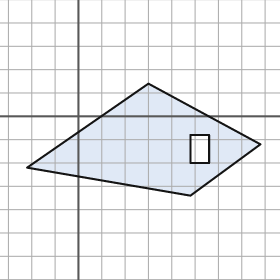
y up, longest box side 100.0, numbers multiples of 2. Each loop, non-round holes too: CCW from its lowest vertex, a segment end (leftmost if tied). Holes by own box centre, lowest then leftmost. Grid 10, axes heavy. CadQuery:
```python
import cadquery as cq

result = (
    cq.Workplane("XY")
    .moveTo(48.0, -34.0)
    .lineTo(78.0, -12.0)
    .lineTo(30.0, 14.0)
    .lineTo(-22.0, -22.0)
    .close()
    .moveTo(48.0, -20.0)
    .lineTo(56.0, -20.0)
    .lineTo(56.0, -8.0)
    .lineTo(48.0, -8.0)
    .close()
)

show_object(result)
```